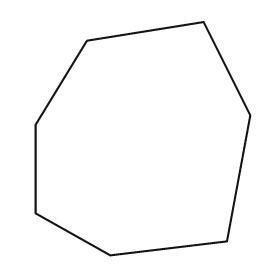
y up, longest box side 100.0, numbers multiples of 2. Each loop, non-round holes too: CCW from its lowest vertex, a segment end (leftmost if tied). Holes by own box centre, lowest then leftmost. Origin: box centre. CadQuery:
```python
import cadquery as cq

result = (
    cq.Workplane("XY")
    .moveTo(-14.0, -50.0)
    .lineTo(36.0, -44.0)
    .lineTo(46.0, 10.0)
    .lineTo(26.0, 50.0)
    .lineTo(-24.0, 42.0)
    .lineTo(-46.0, 6.0)
    .lineTo(-46.0, -32.0)
    .close()
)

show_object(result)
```